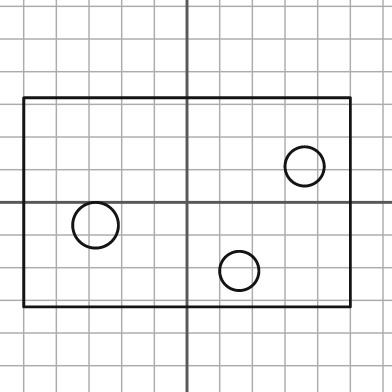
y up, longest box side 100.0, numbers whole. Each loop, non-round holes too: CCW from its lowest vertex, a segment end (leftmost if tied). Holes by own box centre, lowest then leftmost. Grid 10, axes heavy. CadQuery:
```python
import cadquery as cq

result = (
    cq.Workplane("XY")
    .moveTo(-50.0, -32.0)
    .lineTo(50.0, -32.0)
    .lineTo(50.0, 32.0)
    .lineTo(-50.0, 32.0)
    .close()
    .moveTo(16.0, -21.0)
    .circle(6.0)
    .moveTo(-28.0, -7.0)
    .circle(7.0)
    .moveTo(36.0, 11.0)
    .circle(6.0)
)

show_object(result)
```